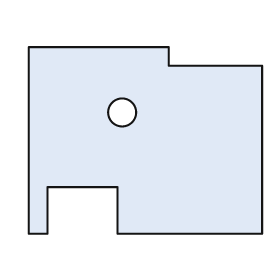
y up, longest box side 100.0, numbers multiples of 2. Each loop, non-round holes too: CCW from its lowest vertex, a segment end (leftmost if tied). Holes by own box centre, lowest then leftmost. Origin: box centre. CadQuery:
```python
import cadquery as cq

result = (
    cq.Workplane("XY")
    .moveTo(-50.0, -40.0)
    .lineTo(-42.0, -40.0)
    .lineTo(-42.0, -20.0)
    .lineTo(-12.0, -20.0)
    .lineTo(-12.0, -40.0)
    .lineTo(50.0, -40.0)
    .lineTo(50.0, 32.0)
    .lineTo(10.0, 32.0)
    .lineTo(10.0, 40.0)
    .lineTo(-50.0, 40.0)
    .close()
    .moveTo(-10.0, 12.0)
    .circle(6.0)
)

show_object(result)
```